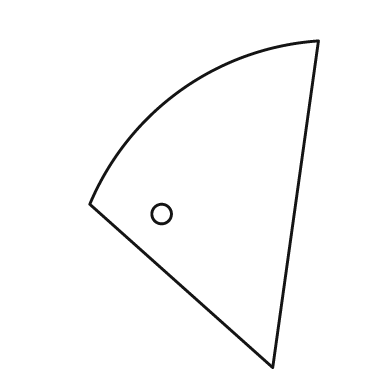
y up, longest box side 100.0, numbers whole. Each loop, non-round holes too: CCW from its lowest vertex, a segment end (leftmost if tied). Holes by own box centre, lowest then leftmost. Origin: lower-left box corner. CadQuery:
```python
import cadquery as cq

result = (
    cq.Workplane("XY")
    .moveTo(56.0, 0.0)
    .lineTo(70.0, 100.0)
    .threePointArc((28.0, 85.0), (0.0, 50.0))
    .close()
    .moveTo(22.0, 47.0)
    .circle(3.0)
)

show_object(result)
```